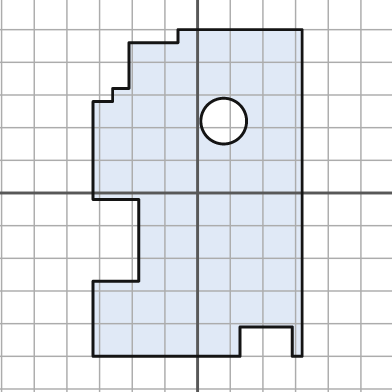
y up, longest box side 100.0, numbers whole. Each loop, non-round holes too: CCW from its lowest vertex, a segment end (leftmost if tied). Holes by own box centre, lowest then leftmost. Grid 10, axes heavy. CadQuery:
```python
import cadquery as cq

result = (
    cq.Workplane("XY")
    .moveTo(-32.0, -50.0)
    .lineTo(13.0, -50.0)
    .lineTo(13.0, -41.0)
    .lineTo(29.0, -41.0)
    .lineTo(29.0, -50.0)
    .lineTo(32.0, -50.0)
    .lineTo(32.0, 50.0)
    .lineTo(-6.0, 50.0)
    .lineTo(-6.0, 46.0)
    .lineTo(-21.0, 46.0)
    .lineTo(-21.0, 32.0)
    .lineTo(-26.0, 32.0)
    .lineTo(-26.0, 28.0)
    .lineTo(-32.0, 28.0)
    .lineTo(-32.0, -2.0)
    .lineTo(-18.0, -2.0)
    .lineTo(-18.0, -27.0)
    .lineTo(-32.0, -27.0)
    .close()
    .moveTo(8.0, 22.0)
    .circle(7.0)
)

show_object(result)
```